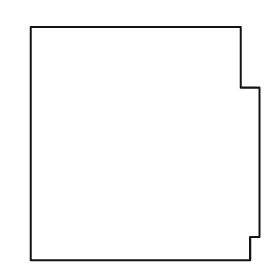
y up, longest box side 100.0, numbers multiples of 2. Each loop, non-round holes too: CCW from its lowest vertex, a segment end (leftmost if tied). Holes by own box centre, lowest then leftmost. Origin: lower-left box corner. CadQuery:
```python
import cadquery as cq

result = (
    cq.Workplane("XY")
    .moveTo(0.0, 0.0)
    .lineTo(94.0, 0.0)
    .lineTo(94.0, 10.0)
    .lineTo(98.0, 10.0)
    .lineTo(98.0, 74.0)
    .lineTo(90.0, 74.0)
    .lineTo(90.0, 100.0)
    .lineTo(0.0, 100.0)
    .close()
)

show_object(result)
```